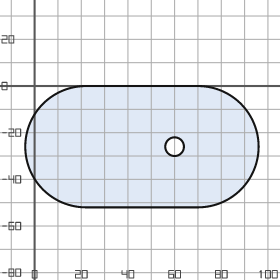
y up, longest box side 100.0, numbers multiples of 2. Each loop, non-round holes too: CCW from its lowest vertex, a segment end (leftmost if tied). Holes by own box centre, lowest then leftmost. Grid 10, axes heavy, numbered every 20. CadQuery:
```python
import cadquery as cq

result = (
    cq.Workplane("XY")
    .moveTo(22.0, -52.0)
    .lineTo(70.0, -52.0)
    .threePointArc((96.0, -26.0), (70.0, 0.0))
    .lineTo(22.0, 0.0)
    .threePointArc((-4.0, -26.0), (22.0, -52.0))
    .close()
    .moveTo(60.0, -26.0)
    .circle(4.0)
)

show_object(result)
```